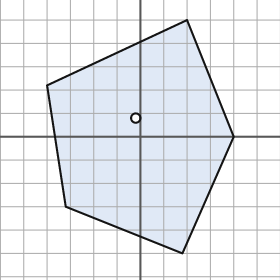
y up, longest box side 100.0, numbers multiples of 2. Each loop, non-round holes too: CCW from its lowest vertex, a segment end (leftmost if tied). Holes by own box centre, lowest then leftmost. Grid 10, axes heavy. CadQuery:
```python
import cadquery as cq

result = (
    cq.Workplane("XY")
    .moveTo(18.0, -50.0)
    .lineTo(40.0, 0.0)
    .lineTo(20.0, 50.0)
    .lineTo(-40.0, 22.0)
    .lineTo(-32.0, -30.0)
    .close()
    .moveTo(-2.0, 8.0)
    .circle(2.0)
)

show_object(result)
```